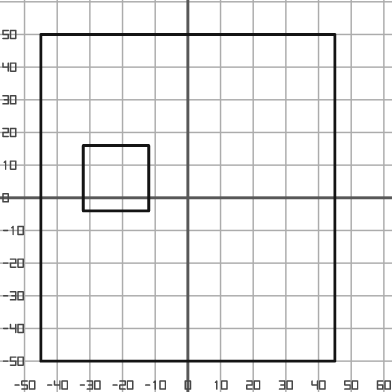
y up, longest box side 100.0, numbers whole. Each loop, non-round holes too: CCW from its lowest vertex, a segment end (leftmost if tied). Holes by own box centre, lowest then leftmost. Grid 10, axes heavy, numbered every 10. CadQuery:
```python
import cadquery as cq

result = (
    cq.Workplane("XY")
    .moveTo(-45.0, -50.0)
    .lineTo(45.0, -50.0)
    .lineTo(45.0, 50.0)
    .lineTo(-45.0, 50.0)
    .close()
    .moveTo(-32.0, -4.0)
    .lineTo(-12.0, -4.0)
    .lineTo(-12.0, 16.0)
    .lineTo(-32.0, 16.0)
    .close()
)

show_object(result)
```